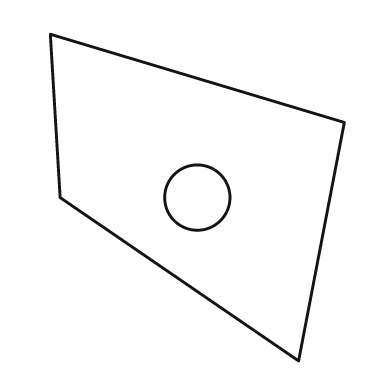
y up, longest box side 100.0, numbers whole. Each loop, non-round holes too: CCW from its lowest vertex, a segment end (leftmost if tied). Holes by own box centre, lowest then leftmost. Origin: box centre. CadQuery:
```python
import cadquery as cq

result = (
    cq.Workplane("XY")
    .moveTo(31.0, -50.0)
    .lineTo(45.0, 23.0)
    .lineTo(-45.0, 50.0)
    .lineTo(-42.0, 0.0)
    .close()
    .moveTo(0.0, 0.0)
    .circle(10.0)
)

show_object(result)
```